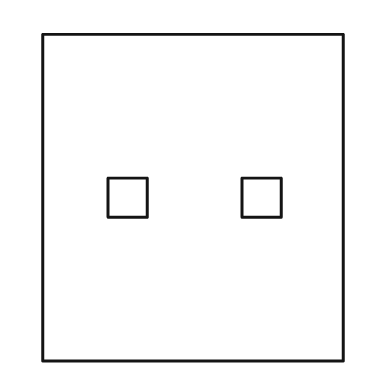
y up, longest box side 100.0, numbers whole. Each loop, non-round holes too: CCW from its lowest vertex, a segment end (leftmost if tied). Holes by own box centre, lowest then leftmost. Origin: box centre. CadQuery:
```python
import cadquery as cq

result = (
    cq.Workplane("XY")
    .moveTo(-46.0, -50.0)
    .lineTo(46.0, -50.0)
    .lineTo(46.0, 50.0)
    .lineTo(-46.0, 50.0)
    .close()
    .moveTo(-26.0, -6.0)
    .lineTo(-14.0, -6.0)
    .lineTo(-14.0, 6.0)
    .lineTo(-26.0, 6.0)
    .close()
    .moveTo(15.0, -6.0)
    .lineTo(27.0, -6.0)
    .lineTo(27.0, 6.0)
    .lineTo(15.0, 6.0)
    .close()
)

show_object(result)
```